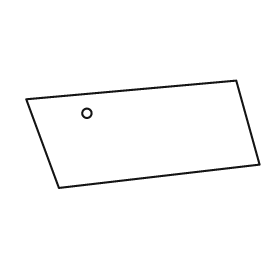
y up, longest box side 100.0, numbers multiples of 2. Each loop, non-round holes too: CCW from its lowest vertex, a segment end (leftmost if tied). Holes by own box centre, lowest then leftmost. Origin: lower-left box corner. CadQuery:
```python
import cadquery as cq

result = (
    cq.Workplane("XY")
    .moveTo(14.0, 0.0)
    .lineTo(100.0, 10.0)
    .lineTo(90.0, 46.0)
    .lineTo(0.0, 38.0)
    .close()
    .moveTo(26.0, 32.0)
    .circle(2.0)
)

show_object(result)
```